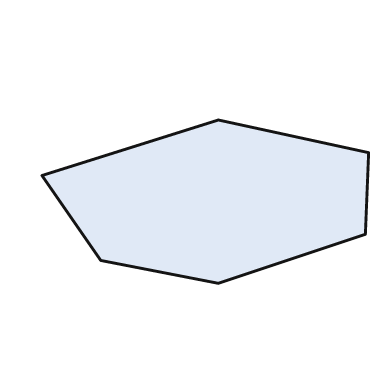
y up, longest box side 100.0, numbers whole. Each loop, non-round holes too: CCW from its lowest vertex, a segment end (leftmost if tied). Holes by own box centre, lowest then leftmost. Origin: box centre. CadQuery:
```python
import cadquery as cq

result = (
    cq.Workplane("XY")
    .moveTo(4.0, -25.0)
    .lineTo(49.0, -10.0)
    .lineTo(50.0, 15.0)
    .lineTo(4.0, 25.0)
    .lineTo(-50.0, 8.0)
    .lineTo(-32.0, -18.0)
    .close()
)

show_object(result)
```